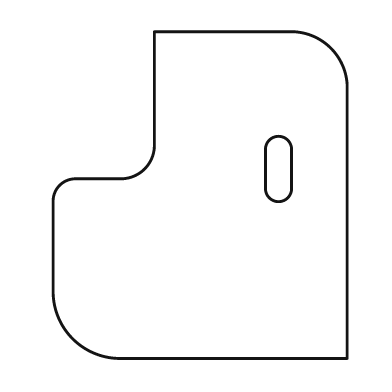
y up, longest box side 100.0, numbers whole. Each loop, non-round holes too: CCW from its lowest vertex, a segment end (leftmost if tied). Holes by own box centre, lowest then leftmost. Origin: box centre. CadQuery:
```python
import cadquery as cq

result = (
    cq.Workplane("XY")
    .moveTo(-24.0, -50.0)
    .lineTo(45.0, -50.0)
    .lineTo(45.0, 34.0)
    .threePointArc((40.0, 45.0), (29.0, 50.0))
    .lineTo(-14.0, 50.0)
    .lineTo(-14.0, 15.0)
    .threePointArc((-17.0, 8.0), (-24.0, 5.0))
    .lineTo(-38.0, 5.0)
    .threePointArc((-43.0, 3.0), (-45.0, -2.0))
    .lineTo(-45.0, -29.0)
    .threePointArc((-39.0, -44.0), (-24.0, -50.0))
    .close()
    .moveTo(20.0, 2.0)
    .threePointArc((24.0, -2.0), (28.0, 2.0))
    .lineTo(28.0, 14.0)
    .threePointArc((24.0, 18.0), (20.0, 14.0))
    .close()
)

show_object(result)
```